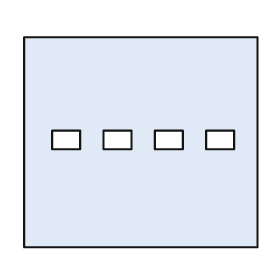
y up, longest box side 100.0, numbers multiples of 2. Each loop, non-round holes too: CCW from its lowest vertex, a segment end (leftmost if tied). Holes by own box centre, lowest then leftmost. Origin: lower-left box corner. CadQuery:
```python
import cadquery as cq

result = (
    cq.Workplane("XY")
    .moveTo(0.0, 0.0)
    .lineTo(100.0, 0.0)
    .lineTo(100.0, 90.0)
    .lineTo(0.0, 90.0)
    .close()
    .moveTo(12.0, 42.0)
    .lineTo(24.0, 42.0)
    .lineTo(24.0, 50.0)
    .lineTo(12.0, 50.0)
    .close()
    .moveTo(34.0, 42.0)
    .lineTo(46.0, 42.0)
    .lineTo(46.0, 50.0)
    .lineTo(34.0, 50.0)
    .close()
    .moveTo(56.0, 42.0)
    .lineTo(68.0, 42.0)
    .lineTo(68.0, 50.0)
    .lineTo(56.0, 50.0)
    .close()
    .moveTo(78.0, 42.0)
    .lineTo(90.0, 42.0)
    .lineTo(90.0, 50.0)
    .lineTo(78.0, 50.0)
    .close()
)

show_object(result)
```